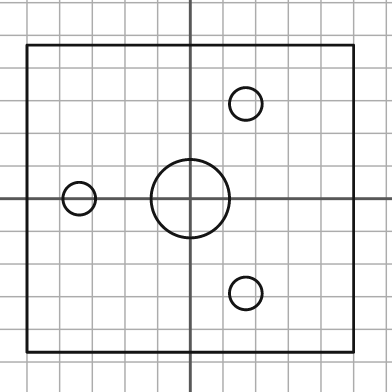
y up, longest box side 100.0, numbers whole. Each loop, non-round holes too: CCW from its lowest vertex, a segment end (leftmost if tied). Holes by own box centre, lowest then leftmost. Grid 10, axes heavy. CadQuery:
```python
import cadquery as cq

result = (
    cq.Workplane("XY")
    .moveTo(-50.0, -47.0)
    .lineTo(50.0, -47.0)
    .lineTo(50.0, 47.0)
    .lineTo(-50.0, 47.0)
    .close()
    .moveTo(17.0, -29.0)
    .circle(5.0)
    .moveTo(-34.0, 0.0)
    .circle(5.0)
    .moveTo(0.0, 0.0)
    .circle(12.0)
    .moveTo(17.0, 29.0)
    .circle(5.0)
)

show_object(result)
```